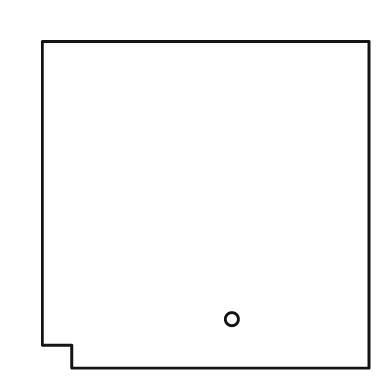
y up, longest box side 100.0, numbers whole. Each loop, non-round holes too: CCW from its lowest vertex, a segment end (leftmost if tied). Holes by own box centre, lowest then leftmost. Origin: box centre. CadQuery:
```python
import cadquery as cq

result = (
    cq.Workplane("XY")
    .moveTo(-41.0, -50.0)
    .lineTo(50.0, -50.0)
    .lineTo(50.0, 50.0)
    .lineTo(-50.0, 50.0)
    .lineTo(-50.0, -43.0)
    .lineTo(-41.0, -43.0)
    .close()
    .moveTo(8.0, -35.0)
    .circle(2.0)
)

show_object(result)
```